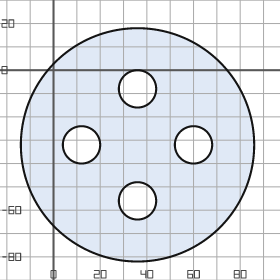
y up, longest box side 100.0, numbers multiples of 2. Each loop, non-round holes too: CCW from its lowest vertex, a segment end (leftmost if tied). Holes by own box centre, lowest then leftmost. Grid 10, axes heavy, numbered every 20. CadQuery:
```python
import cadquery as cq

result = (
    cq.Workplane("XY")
    .moveTo(36.0, -32.0)
    .circle(50.0)
    .moveTo(36.0, -56.0)
    .circle(8.0)
    .moveTo(12.0, -32.0)
    .circle(8.0)
    .moveTo(60.0, -32.0)
    .circle(8.0)
    .moveTo(36.0, -8.0)
    .circle(8.0)
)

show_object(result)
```